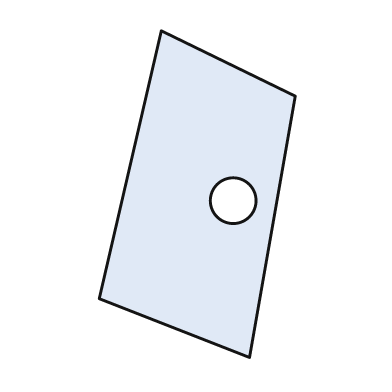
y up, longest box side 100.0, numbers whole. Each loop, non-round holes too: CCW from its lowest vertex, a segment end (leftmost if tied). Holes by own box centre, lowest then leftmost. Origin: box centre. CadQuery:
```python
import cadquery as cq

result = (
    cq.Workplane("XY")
    .moveTo(16.0, -50.0)
    .lineTo(30.0, 30.0)
    .lineTo(-11.0, 50.0)
    .lineTo(-30.0, -32.0)
    .close()
    .moveTo(11.0, -2.0)
    .circle(7.0)
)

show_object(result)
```